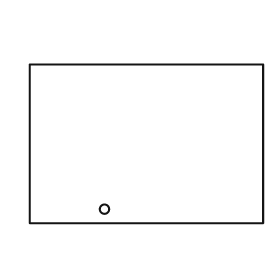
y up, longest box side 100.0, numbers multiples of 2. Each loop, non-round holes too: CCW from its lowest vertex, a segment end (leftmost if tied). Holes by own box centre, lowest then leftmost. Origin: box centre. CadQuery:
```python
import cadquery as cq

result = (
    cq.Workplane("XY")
    .moveTo(-50.0, -34.0)
    .lineTo(50.0, -34.0)
    .lineTo(50.0, 34.0)
    .lineTo(-50.0, 34.0)
    .close()
    .moveTo(-18.0, -28.0)
    .circle(2.0)
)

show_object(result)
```